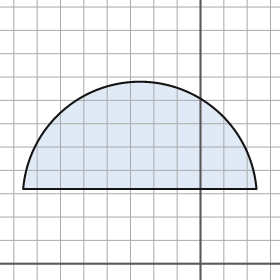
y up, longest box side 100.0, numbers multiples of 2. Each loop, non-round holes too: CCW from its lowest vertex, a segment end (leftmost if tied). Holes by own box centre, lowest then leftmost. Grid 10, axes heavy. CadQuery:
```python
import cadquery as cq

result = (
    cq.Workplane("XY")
    .moveTo(-76.0, 32.0)
    .lineTo(24.0, 32.0)
    .threePointArc((-26.0, 78.0), (-76.0, 32.0))
    .close()
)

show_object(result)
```